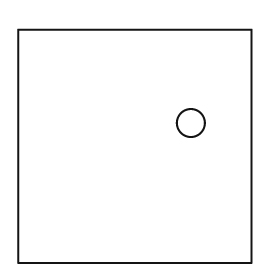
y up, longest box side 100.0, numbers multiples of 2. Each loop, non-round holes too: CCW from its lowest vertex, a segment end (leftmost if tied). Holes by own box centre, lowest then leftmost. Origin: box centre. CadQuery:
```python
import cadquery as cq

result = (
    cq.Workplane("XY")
    .moveTo(-50.0, -50.0)
    .lineTo(50.0, -50.0)
    .lineTo(50.0, 50.0)
    .lineTo(-50.0, 50.0)
    .close()
    .moveTo(24.0, 10.0)
    .circle(6.0)
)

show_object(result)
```